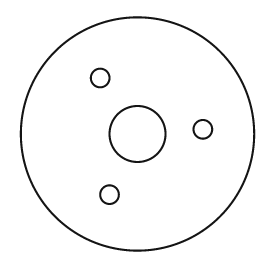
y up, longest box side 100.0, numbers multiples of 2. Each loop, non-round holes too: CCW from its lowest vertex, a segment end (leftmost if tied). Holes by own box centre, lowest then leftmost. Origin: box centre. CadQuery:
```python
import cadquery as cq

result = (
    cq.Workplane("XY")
    .moveTo(0.0, 0.0)
    .circle(50.0)
    .moveTo(-12.0, -26.0)
    .circle(4.0)
    .moveTo(0.0, 0.0)
    .circle(12.0)
    .moveTo(28.0, 2.0)
    .circle(4.0)
    .moveTo(-16.0, 24.0)
    .circle(4.0)
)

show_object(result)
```